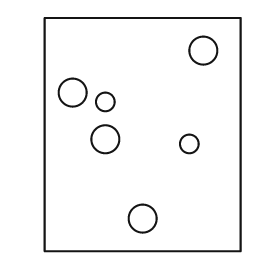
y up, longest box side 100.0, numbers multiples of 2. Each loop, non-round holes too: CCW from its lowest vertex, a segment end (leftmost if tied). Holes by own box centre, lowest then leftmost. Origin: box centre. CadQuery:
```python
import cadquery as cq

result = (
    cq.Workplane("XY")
    .moveTo(-42.0, -50.0)
    .lineTo(42.0, -50.0)
    .lineTo(42.0, 50.0)
    .lineTo(-42.0, 50.0)
    .close()
    .moveTo(0.0, -36.0)
    .circle(6.0)
    .moveTo(20.0, -4.0)
    .circle(4.0)
    .moveTo(-16.0, -2.0)
    .circle(6.0)
    .moveTo(-16.0, 14.0)
    .circle(4.0)
    .moveTo(-30.0, 18.0)
    .circle(6.0)
    .moveTo(26.0, 36.0)
    .circle(6.0)
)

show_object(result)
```